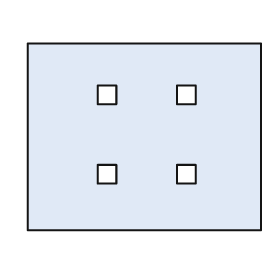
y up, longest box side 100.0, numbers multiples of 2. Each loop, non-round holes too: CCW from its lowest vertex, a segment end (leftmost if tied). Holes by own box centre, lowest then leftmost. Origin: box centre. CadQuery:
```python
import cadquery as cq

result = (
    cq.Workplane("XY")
    .moveTo(-50.0, -40.0)
    .lineTo(50.0, -40.0)
    .lineTo(50.0, 40.0)
    .lineTo(-50.0, 40.0)
    .close()
    .moveTo(-20.0, -20.0)
    .lineTo(-12.0, -20.0)
    .lineTo(-12.0, -12.0)
    .lineTo(-20.0, -12.0)
    .close()
    .moveTo(14.0, -20.0)
    .lineTo(22.0, -20.0)
    .lineTo(22.0, -12.0)
    .lineTo(14.0, -12.0)
    .close()
    .moveTo(-20.0, 14.0)
    .lineTo(-12.0, 14.0)
    .lineTo(-12.0, 22.0)
    .lineTo(-20.0, 22.0)
    .close()
    .moveTo(14.0, 14.0)
    .lineTo(22.0, 14.0)
    .lineTo(22.0, 22.0)
    .lineTo(14.0, 22.0)
    .close()
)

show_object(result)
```